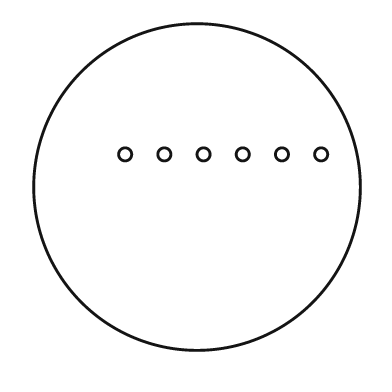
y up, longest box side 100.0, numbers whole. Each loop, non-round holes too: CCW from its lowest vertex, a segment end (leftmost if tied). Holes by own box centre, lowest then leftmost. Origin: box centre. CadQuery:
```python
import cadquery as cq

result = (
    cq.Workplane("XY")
    .moveTo(0.0, 0.0)
    .circle(50.0)
    .moveTo(-22.0, 10.0)
    .circle(2.0)
    .moveTo(-10.0, 10.0)
    .circle(2.0)
    .moveTo(2.0, 10.0)
    .circle(2.0)
    .moveTo(14.0, 10.0)
    .circle(2.0)
    .moveTo(26.0, 10.0)
    .circle(2.0)
    .moveTo(38.0, 10.0)
    .circle(2.0)
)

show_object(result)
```